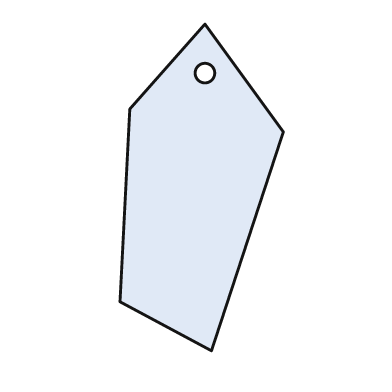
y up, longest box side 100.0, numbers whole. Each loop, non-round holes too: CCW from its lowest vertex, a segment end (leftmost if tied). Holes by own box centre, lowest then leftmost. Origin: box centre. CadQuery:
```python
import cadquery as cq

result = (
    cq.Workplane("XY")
    .moveTo(3.0, -50.0)
    .lineTo(25.0, 17.0)
    .lineTo(1.0, 50.0)
    .lineTo(-22.0, 24.0)
    .lineTo(-25.0, -35.0)
    .close()
    .moveTo(1.0, 35.0)
    .circle(3.0)
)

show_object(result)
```